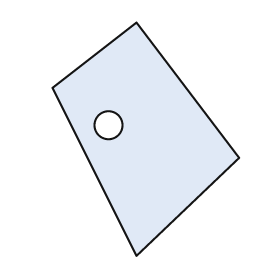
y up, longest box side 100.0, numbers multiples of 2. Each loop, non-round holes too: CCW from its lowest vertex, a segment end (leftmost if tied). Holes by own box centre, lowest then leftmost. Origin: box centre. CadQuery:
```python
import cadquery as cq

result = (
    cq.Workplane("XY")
    .moveTo(-4.0, -50.0)
    .lineTo(40.0, -8.0)
    .lineTo(-4.0, 50.0)
    .lineTo(-40.0, 22.0)
    .close()
    .moveTo(-16.0, 6.0)
    .circle(6.0)
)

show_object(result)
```